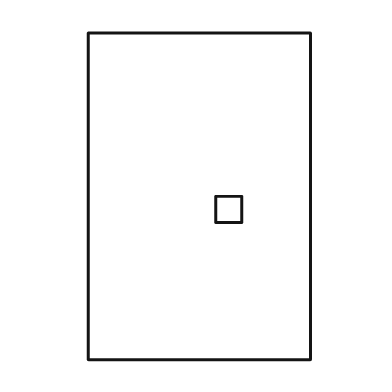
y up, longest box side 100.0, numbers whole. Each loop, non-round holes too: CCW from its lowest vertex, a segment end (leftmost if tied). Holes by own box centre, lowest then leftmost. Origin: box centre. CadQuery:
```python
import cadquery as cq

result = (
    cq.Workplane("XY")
    .moveTo(-34.0, -50.0)
    .lineTo(34.0, -50.0)
    .lineTo(34.0, 50.0)
    .lineTo(-34.0, 50.0)
    .close()
    .moveTo(5.0, -8.0)
    .lineTo(13.0, -8.0)
    .lineTo(13.0, 0.0)
    .lineTo(5.0, 0.0)
    .close()
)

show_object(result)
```